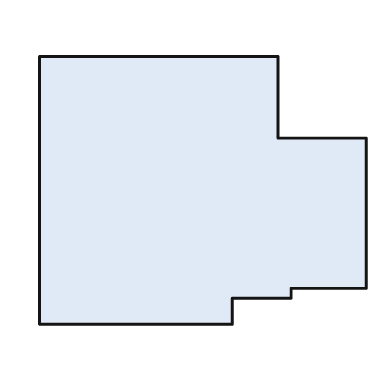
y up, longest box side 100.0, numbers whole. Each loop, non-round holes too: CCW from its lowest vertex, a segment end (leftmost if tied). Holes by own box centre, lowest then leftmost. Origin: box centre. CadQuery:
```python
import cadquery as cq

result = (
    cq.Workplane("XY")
    .moveTo(-50.0, -41.0)
    .lineTo(9.0, -41.0)
    .lineTo(9.0, -33.0)
    .lineTo(27.0, -33.0)
    .lineTo(27.0, -30.0)
    .lineTo(50.0, -30.0)
    .lineTo(50.0, 16.0)
    .lineTo(23.0, 16.0)
    .lineTo(23.0, 41.0)
    .lineTo(-50.0, 41.0)
    .close()
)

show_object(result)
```